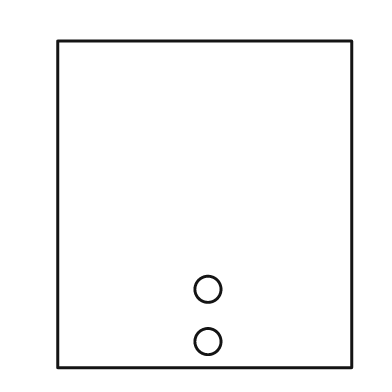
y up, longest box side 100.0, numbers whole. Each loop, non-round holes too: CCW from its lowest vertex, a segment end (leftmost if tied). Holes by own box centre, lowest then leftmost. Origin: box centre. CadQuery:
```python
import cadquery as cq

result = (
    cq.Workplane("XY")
    .moveTo(-45.0, -50.0)
    .lineTo(45.0, -50.0)
    .lineTo(45.0, 50.0)
    .lineTo(-45.0, 50.0)
    .close()
    .moveTo(1.0, -42.0)
    .circle(4.0)
    .moveTo(1.0, -26.0)
    .circle(4.0)
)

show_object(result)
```